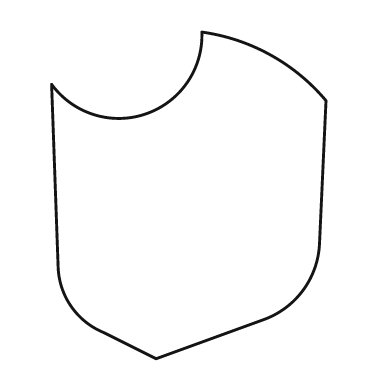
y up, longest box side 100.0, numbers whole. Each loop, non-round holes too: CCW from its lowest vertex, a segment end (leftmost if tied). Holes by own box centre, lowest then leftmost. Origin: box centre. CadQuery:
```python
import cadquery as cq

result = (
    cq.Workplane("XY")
    .moveTo(-10.0, -50.0)
    .lineTo(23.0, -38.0)
    .threePointArc((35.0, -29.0), (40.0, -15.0))
    .lineTo(42.0, 29.0)
    .threePointArc((25.0, 43.0), (4.0, 50.0))
    .threePointArc((-13.0, 25.0), (-42.0, 34.0))
    .lineTo(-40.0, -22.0)
    .threePointArc((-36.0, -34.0), (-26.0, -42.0))
    .close()
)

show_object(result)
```